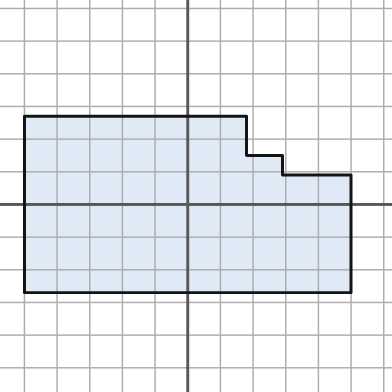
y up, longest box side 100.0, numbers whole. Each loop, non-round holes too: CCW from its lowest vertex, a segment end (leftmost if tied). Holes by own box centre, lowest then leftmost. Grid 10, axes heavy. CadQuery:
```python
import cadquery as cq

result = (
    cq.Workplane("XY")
    .moveTo(-50.0, -27.0)
    .lineTo(50.0, -27.0)
    .lineTo(50.0, 9.0)
    .lineTo(29.0, 9.0)
    .lineTo(29.0, 15.0)
    .lineTo(18.0, 15.0)
    .lineTo(18.0, 27.0)
    .lineTo(-50.0, 27.0)
    .close()
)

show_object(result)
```